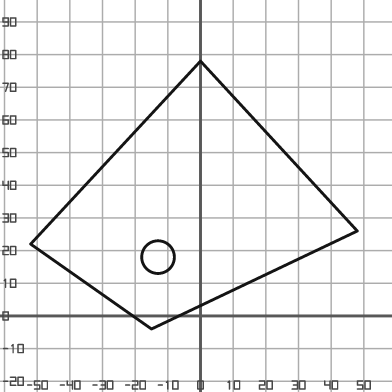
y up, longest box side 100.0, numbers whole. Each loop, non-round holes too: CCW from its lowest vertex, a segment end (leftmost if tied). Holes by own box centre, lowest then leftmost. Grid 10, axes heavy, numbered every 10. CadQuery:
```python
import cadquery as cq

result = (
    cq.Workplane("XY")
    .moveTo(-15.0, -4.0)
    .lineTo(48.0, 26.0)
    .lineTo(0.0, 78.0)
    .lineTo(-52.0, 22.0)
    .close()
    .moveTo(-13.0, 18.0)
    .circle(5.0)
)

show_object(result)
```